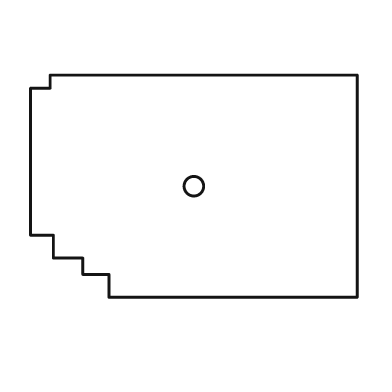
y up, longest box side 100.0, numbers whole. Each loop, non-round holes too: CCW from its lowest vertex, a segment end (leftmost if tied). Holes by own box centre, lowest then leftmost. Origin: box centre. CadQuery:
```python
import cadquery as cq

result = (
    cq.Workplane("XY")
    .moveTo(-26.0, -34.0)
    .lineTo(50.0, -34.0)
    .lineTo(50.0, 34.0)
    .lineTo(-44.0, 34.0)
    .lineTo(-44.0, 30.0)
    .lineTo(-50.0, 30.0)
    .lineTo(-50.0, -15.0)
    .lineTo(-43.0, -15.0)
    .lineTo(-43.0, -22.0)
    .lineTo(-34.0, -22.0)
    .lineTo(-34.0, -27.0)
    .lineTo(-26.0, -27.0)
    .close()
    .moveTo(0.0, 0.0)
    .circle(3.0)
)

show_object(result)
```